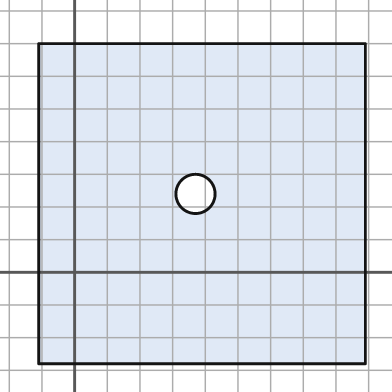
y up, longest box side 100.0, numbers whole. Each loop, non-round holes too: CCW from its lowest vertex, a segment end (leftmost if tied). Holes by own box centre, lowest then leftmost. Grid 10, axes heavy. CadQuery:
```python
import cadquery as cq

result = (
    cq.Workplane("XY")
    .moveTo(-11.0, -28.0)
    .lineTo(89.0, -28.0)
    .lineTo(89.0, 70.0)
    .lineTo(-11.0, 70.0)
    .close()
    .moveTo(37.0, 24.0)
    .circle(6.0)
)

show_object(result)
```